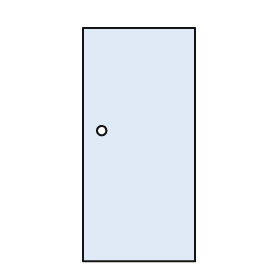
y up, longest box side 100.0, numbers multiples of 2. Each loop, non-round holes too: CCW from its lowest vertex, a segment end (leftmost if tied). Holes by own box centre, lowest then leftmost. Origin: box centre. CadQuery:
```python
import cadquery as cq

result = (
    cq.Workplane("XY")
    .moveTo(-24.0, -50.0)
    .lineTo(24.0, -50.0)
    .lineTo(24.0, 50.0)
    .lineTo(-24.0, 50.0)
    .close()
    .moveTo(-16.0, 6.0)
    .circle(2.0)
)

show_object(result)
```